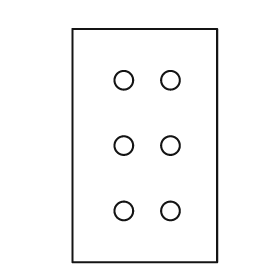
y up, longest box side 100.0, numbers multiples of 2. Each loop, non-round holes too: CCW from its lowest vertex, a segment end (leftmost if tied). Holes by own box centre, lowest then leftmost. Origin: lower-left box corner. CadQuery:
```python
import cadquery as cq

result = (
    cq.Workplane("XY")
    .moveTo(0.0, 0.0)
    .lineTo(62.0, 0.0)
    .lineTo(62.0, 100.0)
    .lineTo(0.0, 100.0)
    .close()
    .moveTo(22.0, 22.0)
    .circle(4.0)
    .moveTo(42.0, 22.0)
    .circle(4.0)
    .moveTo(22.0, 50.0)
    .circle(4.0)
    .moveTo(42.0, 50.0)
    .circle(4.0)
    .moveTo(22.0, 78.0)
    .circle(4.0)
    .moveTo(42.0, 78.0)
    .circle(4.0)
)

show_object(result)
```